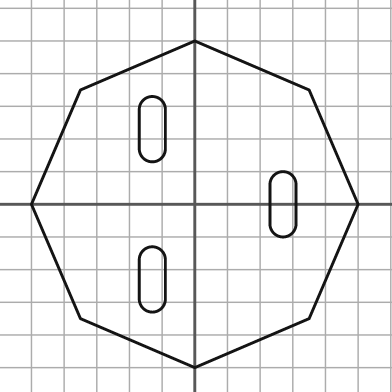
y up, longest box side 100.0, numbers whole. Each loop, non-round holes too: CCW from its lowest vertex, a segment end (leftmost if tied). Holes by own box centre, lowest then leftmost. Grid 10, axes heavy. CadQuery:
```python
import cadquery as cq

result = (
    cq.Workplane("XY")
    .moveTo(0.0, -50.0)
    .lineTo(35.0, -35.0)
    .lineTo(50.0, 0.0)
    .lineTo(35.0, 35.0)
    .lineTo(0.0, 50.0)
    .lineTo(-35.0, 35.0)
    .lineTo(-50.0, 0.0)
    .lineTo(-35.0, -35.0)
    .close()
    .moveTo(-17.0, -29.0)
    .threePointArc((-13.0, -33.0), (-9.0, -29.0))
    .lineTo(-9.0, -17.0)
    .threePointArc((-13.0, -13.0), (-17.0, -17.0))
    .close()
    .moveTo(23.0, -6.0)
    .threePointArc((27.0, -10.0), (31.0, -6.0))
    .lineTo(31.0, 6.0)
    .threePointArc((27.0, 10.0), (23.0, 6.0))
    .close()
    .moveTo(-17.0, 17.0)
    .threePointArc((-13.0, 13.0), (-9.0, 17.0))
    .lineTo(-9.0, 29.0)
    .threePointArc((-13.0, 33.0), (-17.0, 29.0))
    .close()
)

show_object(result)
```